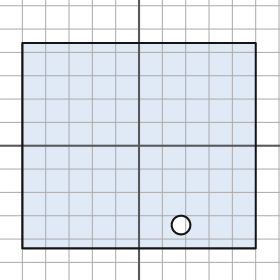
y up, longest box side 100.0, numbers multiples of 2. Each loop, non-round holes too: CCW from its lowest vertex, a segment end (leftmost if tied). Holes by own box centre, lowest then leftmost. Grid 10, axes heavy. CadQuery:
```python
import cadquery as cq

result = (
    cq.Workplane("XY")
    .moveTo(-50.0, -44.0)
    .lineTo(50.0, -44.0)
    .lineTo(50.0, 44.0)
    .lineTo(-50.0, 44.0)
    .close()
    .moveTo(18.0, -34.0)
    .circle(4.0)
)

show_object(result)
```